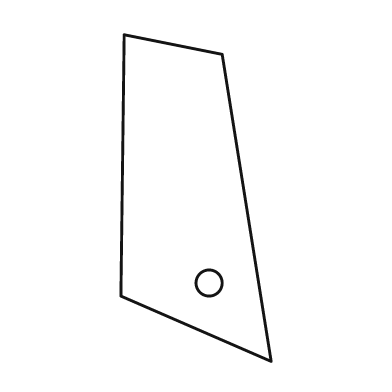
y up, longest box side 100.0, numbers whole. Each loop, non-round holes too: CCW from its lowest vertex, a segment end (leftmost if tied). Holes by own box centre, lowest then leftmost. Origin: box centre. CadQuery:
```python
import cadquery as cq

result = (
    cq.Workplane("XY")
    .moveTo(23.0, -50.0)
    .lineTo(8.0, 44.0)
    .lineTo(-22.0, 50.0)
    .lineTo(-23.0, -30.0)
    .close()
    .moveTo(4.0, -26.0)
    .circle(4.0)
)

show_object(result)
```